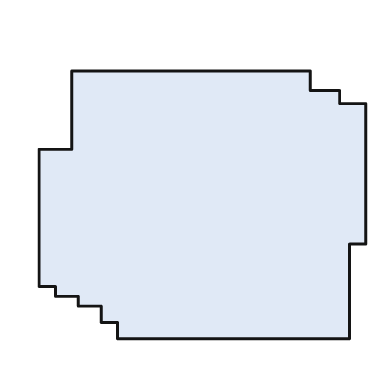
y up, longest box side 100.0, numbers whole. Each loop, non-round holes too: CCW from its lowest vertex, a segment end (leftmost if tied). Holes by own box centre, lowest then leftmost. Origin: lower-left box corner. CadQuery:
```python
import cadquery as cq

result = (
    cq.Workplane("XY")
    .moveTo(24.0, 0.0)
    .lineTo(95.0, 0.0)
    .lineTo(95.0, 29.0)
    .lineTo(100.0, 29.0)
    .lineTo(100.0, 72.0)
    .lineTo(92.0, 72.0)
    .lineTo(92.0, 76.0)
    .lineTo(83.0, 76.0)
    .lineTo(83.0, 82.0)
    .lineTo(10.0, 82.0)
    .lineTo(10.0, 58.0)
    .lineTo(0.0, 58.0)
    .lineTo(0.0, 16.0)
    .lineTo(5.0, 16.0)
    .lineTo(5.0, 13.0)
    .lineTo(12.0, 13.0)
    .lineTo(12.0, 10.0)
    .lineTo(19.0, 10.0)
    .lineTo(19.0, 5.0)
    .lineTo(24.0, 5.0)
    .close()
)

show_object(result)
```